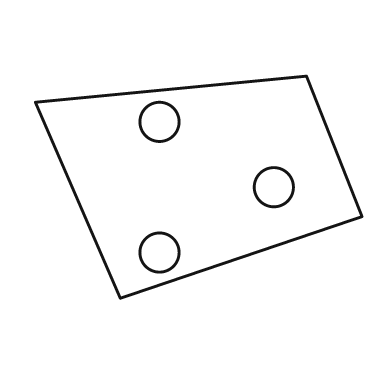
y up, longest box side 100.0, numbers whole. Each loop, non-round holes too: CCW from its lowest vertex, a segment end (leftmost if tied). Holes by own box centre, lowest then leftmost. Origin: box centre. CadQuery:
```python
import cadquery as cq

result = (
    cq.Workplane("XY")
    .moveTo(-24.0, -34.0)
    .lineTo(50.0, -9.0)
    .lineTo(33.0, 34.0)
    .lineTo(-50.0, 26.0)
    .close()
    .moveTo(-12.0, -20.0)
    .circle(6.0)
    .moveTo(23.0, 0.0)
    .circle(6.0)
    .moveTo(-12.0, 20.0)
    .circle(6.0)
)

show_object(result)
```